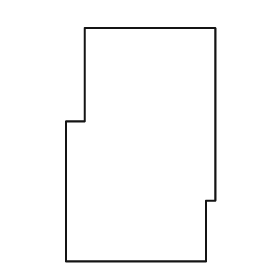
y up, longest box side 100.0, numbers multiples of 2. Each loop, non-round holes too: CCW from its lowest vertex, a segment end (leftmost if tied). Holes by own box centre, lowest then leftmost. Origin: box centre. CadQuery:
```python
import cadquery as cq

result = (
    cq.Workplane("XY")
    .moveTo(-32.0, -50.0)
    .lineTo(28.0, -50.0)
    .lineTo(28.0, -24.0)
    .lineTo(32.0, -24.0)
    .lineTo(32.0, 50.0)
    .lineTo(-24.0, 50.0)
    .lineTo(-24.0, 10.0)
    .lineTo(-32.0, 10.0)
    .close()
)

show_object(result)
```